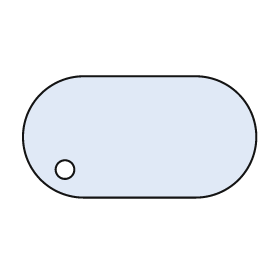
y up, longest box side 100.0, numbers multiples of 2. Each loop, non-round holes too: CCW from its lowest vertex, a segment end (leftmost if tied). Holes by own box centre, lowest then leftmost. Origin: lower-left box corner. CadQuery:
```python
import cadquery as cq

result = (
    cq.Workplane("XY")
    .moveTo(26.0, 0.0)
    .lineTo(74.0, 0.0)
    .threePointArc((100.0, 26.0), (74.0, 52.0))
    .lineTo(26.0, 52.0)
    .threePointArc((0.0, 26.0), (26.0, 0.0))
    .close()
    .moveTo(18.0, 12.0)
    .circle(4.0)
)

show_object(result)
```